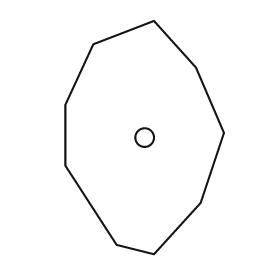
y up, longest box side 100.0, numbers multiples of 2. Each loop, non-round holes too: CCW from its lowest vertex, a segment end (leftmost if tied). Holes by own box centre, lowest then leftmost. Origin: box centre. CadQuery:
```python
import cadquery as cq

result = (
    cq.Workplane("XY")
    .moveTo(4.0, -50.0)
    .lineTo(24.0, -28.0)
    .lineTo(34.0, 2.0)
    .lineTo(22.0, 30.0)
    .lineTo(4.0, 50.0)
    .lineTo(-22.0, 40.0)
    .lineTo(-34.0, 14.0)
    .lineTo(-34.0, -12.0)
    .lineTo(-12.0, -46.0)
    .close()
    .moveTo(0.0, 0.0)
    .circle(4.0)
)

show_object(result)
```